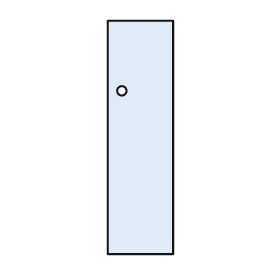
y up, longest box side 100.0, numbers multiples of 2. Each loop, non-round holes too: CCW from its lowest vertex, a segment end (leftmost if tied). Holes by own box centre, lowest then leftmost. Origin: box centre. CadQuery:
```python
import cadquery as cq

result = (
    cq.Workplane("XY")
    .moveTo(-14.0, -50.0)
    .lineTo(14.0, -50.0)
    .lineTo(14.0, 50.0)
    .lineTo(-14.0, 50.0)
    .close()
    .moveTo(-8.0, 20.0)
    .circle(2.0)
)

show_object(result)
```